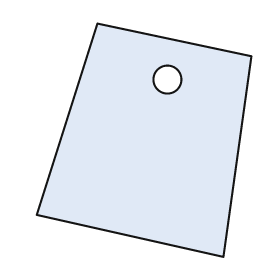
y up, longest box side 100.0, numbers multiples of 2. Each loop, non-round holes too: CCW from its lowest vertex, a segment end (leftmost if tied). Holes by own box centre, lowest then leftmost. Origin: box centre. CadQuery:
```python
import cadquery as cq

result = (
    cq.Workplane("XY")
    .moveTo(34.0, -50.0)
    .lineTo(46.0, 36.0)
    .lineTo(-20.0, 50.0)
    .lineTo(-46.0, -32.0)
    .close()
    .moveTo(10.0, 26.0)
    .circle(6.0)
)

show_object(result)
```